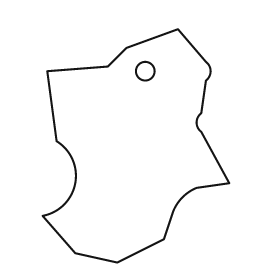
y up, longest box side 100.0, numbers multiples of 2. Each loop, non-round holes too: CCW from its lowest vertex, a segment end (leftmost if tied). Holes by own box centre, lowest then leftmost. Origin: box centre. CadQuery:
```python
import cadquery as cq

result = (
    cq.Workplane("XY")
    .moveTo(-8.0, -50.0)
    .lineTo(12.0, -40.0)
    .lineTo(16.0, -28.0)
    .threePointArc((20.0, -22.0), (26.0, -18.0))
    .lineTo(40.0, -16.0)
    .lineTo(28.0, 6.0)
    .threePointArc((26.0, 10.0), (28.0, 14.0))
    .lineTo(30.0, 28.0)
    .threePointArc((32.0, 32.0), (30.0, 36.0))
    .lineTo(18.0, 50.0)
    .lineTo(-4.0, 42.0)
    .lineTo(-12.0, 34.0)
    .lineTo(-38.0, 32.0)
    .lineTo(-34.0, 2.0)
    .threePointArc((-26.0, -16.0), (-40.0, -30.0))
    .lineTo(-26.0, -46.0)
    .close()
    .moveTo(4.0, 32.0)
    .circle(4.0)
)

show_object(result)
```